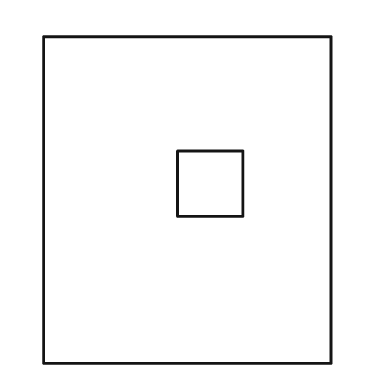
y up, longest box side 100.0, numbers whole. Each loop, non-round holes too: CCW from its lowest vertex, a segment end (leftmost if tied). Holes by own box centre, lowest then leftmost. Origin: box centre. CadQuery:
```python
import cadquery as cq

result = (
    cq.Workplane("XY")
    .moveTo(-44.0, -50.0)
    .lineTo(44.0, -50.0)
    .lineTo(44.0, 50.0)
    .lineTo(-44.0, 50.0)
    .close()
    .moveTo(-3.0, -5.0)
    .lineTo(17.0, -5.0)
    .lineTo(17.0, 15.0)
    .lineTo(-3.0, 15.0)
    .close()
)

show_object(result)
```